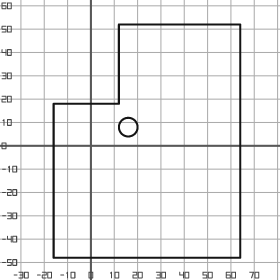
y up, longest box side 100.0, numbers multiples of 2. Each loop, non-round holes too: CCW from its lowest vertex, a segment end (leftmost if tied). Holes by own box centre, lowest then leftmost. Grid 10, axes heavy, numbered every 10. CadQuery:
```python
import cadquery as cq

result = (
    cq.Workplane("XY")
    .moveTo(-16.0, -48.0)
    .lineTo(64.0, -48.0)
    .lineTo(64.0, 52.0)
    .lineTo(12.0, 52.0)
    .lineTo(12.0, 18.0)
    .lineTo(-16.0, 18.0)
    .close()
    .moveTo(16.0, 8.0)
    .circle(4.0)
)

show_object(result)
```